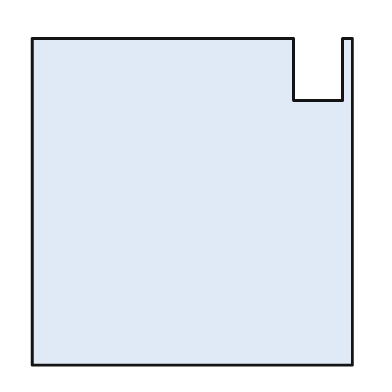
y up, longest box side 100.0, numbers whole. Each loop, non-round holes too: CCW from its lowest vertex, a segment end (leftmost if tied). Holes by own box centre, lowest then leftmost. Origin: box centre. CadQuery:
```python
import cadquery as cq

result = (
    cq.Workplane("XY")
    .moveTo(-49.0, -50.0)
    .lineTo(49.0, -50.0)
    .lineTo(49.0, 50.0)
    .lineTo(46.0, 50.0)
    .lineTo(46.0, 31.0)
    .lineTo(31.0, 31.0)
    .lineTo(31.0, 50.0)
    .lineTo(-49.0, 50.0)
    .close()
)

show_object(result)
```